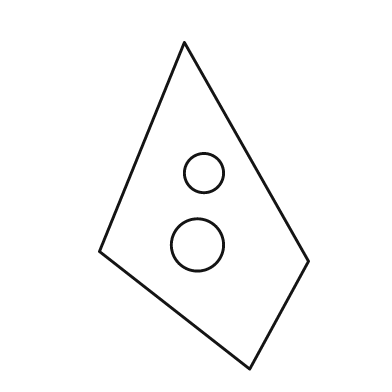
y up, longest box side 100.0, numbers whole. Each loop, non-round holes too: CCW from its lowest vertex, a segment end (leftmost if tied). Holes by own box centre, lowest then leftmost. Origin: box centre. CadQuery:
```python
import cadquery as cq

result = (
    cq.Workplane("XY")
    .moveTo(14.0, -50.0)
    .lineTo(32.0, -17.0)
    .lineTo(-6.0, 50.0)
    .lineTo(-32.0, -14.0)
    .close()
    .moveTo(-2.0, -12.0)
    .circle(8.0)
    .moveTo(0.0, 10.0)
    .circle(6.0)
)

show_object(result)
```